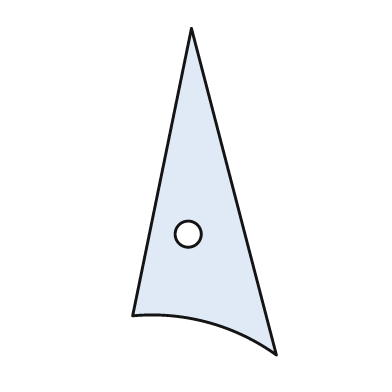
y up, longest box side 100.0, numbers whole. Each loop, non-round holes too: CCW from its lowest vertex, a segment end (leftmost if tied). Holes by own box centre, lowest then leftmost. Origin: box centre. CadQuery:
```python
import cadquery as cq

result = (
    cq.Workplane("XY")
    .moveTo(22.0, -50.0)
    .lineTo(-4.0, 50.0)
    .lineTo(-22.0, -38.0)
    .threePointArc((1.0, -40.0), (22.0, -50.0))
    .close()
    .moveTo(-5.0, -13.0)
    .circle(4.0)
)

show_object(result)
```